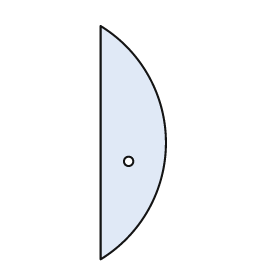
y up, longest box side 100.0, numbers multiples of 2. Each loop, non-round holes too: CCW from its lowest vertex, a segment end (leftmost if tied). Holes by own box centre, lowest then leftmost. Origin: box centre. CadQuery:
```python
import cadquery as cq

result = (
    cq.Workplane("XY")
    .moveTo(-14.0, -50.0)
    .threePointArc((14.0, 0.0), (-14.0, 50.0))
    .close()
    .moveTo(-2.0, -8.0)
    .circle(2.0)
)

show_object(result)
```